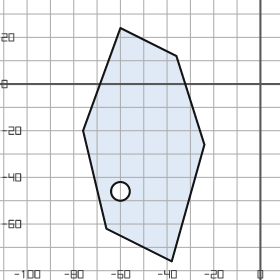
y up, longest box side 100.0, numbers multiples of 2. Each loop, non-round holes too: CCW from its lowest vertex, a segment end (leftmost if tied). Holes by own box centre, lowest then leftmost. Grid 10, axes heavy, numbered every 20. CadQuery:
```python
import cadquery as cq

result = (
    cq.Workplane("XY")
    .moveTo(-38.0, -76.0)
    .lineTo(-24.0, -26.0)
    .lineTo(-36.0, 12.0)
    .lineTo(-60.0, 24.0)
    .lineTo(-76.0, -20.0)
    .lineTo(-66.0, -62.0)
    .close()
    .moveTo(-60.0, -46.0)
    .circle(4.0)
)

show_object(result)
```